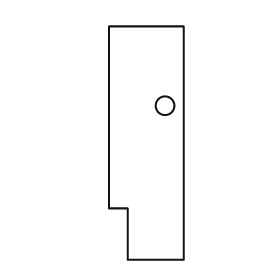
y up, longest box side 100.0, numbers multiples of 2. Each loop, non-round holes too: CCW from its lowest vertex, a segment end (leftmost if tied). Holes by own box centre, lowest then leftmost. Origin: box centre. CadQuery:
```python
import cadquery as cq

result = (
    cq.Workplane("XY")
    .moveTo(-8.0, -50.0)
    .lineTo(16.0, -50.0)
    .lineTo(16.0, 50.0)
    .lineTo(-16.0, 50.0)
    .lineTo(-16.0, -28.0)
    .lineTo(-8.0, -28.0)
    .close()
    .moveTo(8.0, 16.0)
    .circle(4.0)
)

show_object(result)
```